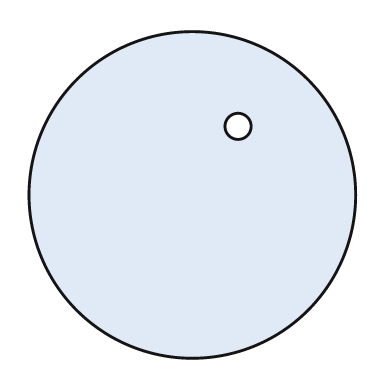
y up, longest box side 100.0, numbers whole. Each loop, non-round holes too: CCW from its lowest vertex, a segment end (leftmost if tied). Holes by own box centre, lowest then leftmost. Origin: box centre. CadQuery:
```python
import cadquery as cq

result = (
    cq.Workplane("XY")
    .moveTo(0.0, 0.0)
    .circle(50.0)
    .moveTo(14.0, 21.0)
    .circle(4.0)
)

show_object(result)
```